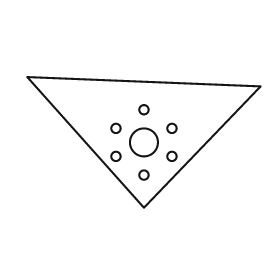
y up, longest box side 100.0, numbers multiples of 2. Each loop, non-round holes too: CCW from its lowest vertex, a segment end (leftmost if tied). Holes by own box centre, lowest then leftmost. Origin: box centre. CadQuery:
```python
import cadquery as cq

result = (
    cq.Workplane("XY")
    .moveTo(0.0, -28.0)
    .lineTo(50.0, 24.0)
    .lineTo(-50.0, 28.0)
    .close()
    .moveTo(0.0, -14.0)
    .circle(2.0)
    .moveTo(-12.0, -6.0)
    .circle(2.0)
    .moveTo(12.0, -6.0)
    .circle(2.0)
    .moveTo(0.0, 0.0)
    .circle(6.0)
    .moveTo(-12.0, 6.0)
    .circle(2.0)
    .moveTo(12.0, 6.0)
    .circle(2.0)
    .moveTo(0.0, 14.0)
    .circle(2.0)
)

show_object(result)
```